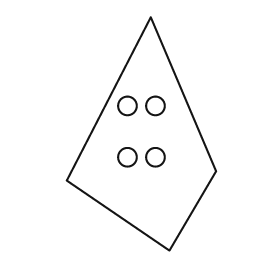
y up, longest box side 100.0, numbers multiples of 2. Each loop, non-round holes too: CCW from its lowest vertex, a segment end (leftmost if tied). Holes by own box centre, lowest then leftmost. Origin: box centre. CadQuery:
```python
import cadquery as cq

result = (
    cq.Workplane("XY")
    .moveTo(12.0, -50.0)
    .lineTo(32.0, -16.0)
    .lineTo(4.0, 50.0)
    .lineTo(-32.0, -20.0)
    .close()
    .moveTo(-6.0, -10.0)
    .circle(4.0)
    .moveTo(6.0, -10.0)
    .circle(4.0)
    .moveTo(-6.0, 12.0)
    .circle(4.0)
    .moveTo(6.0, 12.0)
    .circle(4.0)
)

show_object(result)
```